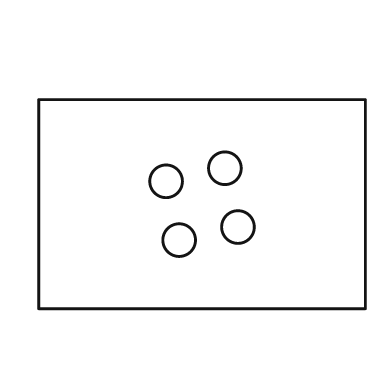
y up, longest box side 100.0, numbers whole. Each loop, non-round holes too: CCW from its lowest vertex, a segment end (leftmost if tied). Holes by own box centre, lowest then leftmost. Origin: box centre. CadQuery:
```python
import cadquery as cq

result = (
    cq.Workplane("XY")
    .moveTo(-50.0, -32.0)
    .lineTo(50.0, -32.0)
    .lineTo(50.0, 32.0)
    .lineTo(-50.0, 32.0)
    .close()
    .moveTo(-7.0, -11.0)
    .circle(5.0)
    .moveTo(11.0, -7.0)
    .circle(5.0)
    .moveTo(-11.0, 7.0)
    .circle(5.0)
    .moveTo(7.0, 11.0)
    .circle(5.0)
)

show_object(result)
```